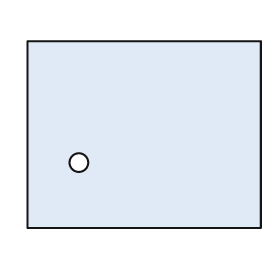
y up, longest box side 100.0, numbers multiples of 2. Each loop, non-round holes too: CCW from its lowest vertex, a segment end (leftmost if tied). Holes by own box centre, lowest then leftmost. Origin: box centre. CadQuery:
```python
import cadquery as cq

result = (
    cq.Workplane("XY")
    .moveTo(-50.0, -40.0)
    .lineTo(50.0, -40.0)
    .lineTo(50.0, 40.0)
    .lineTo(-50.0, 40.0)
    .close()
    .moveTo(-28.0, -12.0)
    .circle(4.0)
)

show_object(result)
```